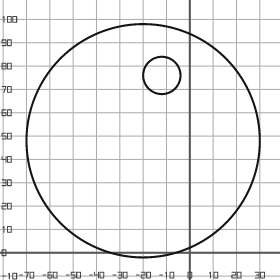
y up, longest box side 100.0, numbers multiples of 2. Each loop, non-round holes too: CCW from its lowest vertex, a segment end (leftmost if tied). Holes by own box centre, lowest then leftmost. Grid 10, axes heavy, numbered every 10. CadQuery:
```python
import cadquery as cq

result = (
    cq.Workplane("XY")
    .moveTo(-20.0, 48.0)
    .circle(50.0)
    .moveTo(-12.0, 76.0)
    .circle(8.0)
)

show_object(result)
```